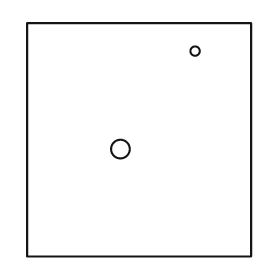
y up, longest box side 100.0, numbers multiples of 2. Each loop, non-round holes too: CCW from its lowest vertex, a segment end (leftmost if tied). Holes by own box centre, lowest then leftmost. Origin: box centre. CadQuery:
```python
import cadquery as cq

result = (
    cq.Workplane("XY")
    .moveTo(-48.0, -50.0)
    .lineTo(48.0, -50.0)
    .lineTo(48.0, 50.0)
    .lineTo(-48.0, 50.0)
    .close()
    .moveTo(-8.0, -4.0)
    .circle(4.0)
    .moveTo(24.0, 38.0)
    .circle(2.0)
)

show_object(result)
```